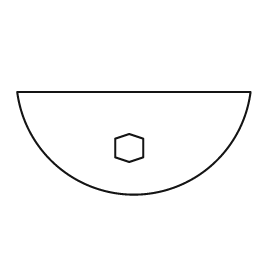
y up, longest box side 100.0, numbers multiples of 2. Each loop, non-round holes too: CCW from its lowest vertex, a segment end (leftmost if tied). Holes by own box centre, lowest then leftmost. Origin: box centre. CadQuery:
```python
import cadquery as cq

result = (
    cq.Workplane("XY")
    .moveTo(-50.0, 22.0)
    .threePointArc((0.0, -22.0), (50.0, 22.0))
    .close()
    .moveTo(-2.0, -8.0)
    .lineTo(4.0, -6.0)
    .lineTo(4.0, 2.0)
    .lineTo(-2.0, 4.0)
    .lineTo(-8.0, 2.0)
    .lineTo(-8.0, -6.0)
    .close()
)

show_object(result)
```